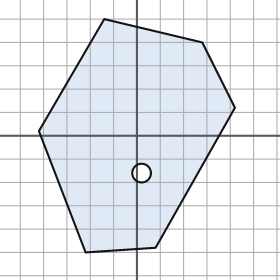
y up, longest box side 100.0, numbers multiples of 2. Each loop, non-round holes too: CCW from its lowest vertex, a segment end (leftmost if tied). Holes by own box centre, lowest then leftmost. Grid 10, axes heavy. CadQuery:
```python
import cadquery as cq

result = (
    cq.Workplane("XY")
    .moveTo(-22.0, -50.0)
    .lineTo(8.0, -48.0)
    .lineTo(42.0, 12.0)
    .lineTo(28.0, 40.0)
    .lineTo(-14.0, 50.0)
    .lineTo(-42.0, 2.0)
    .close()
    .moveTo(2.0, -16.0)
    .circle(4.0)
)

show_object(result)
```